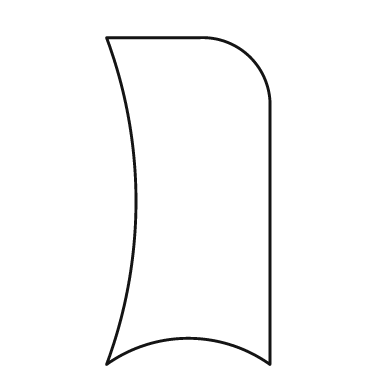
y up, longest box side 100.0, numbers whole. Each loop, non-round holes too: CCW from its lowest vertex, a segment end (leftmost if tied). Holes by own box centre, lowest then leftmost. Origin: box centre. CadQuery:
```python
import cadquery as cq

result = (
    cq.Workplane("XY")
    .moveTo(-25.0, -50.0)
    .threePointArc((0.0, -42.0), (25.0, -50.0))
    .lineTo(25.0, 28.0)
    .threePointArc((19.0, 44.0), (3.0, 50.0))
    .lineTo(-25.0, 50.0)
    .threePointArc((-16.0, 0.0), (-25.0, -50.0))
    .close()
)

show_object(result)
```